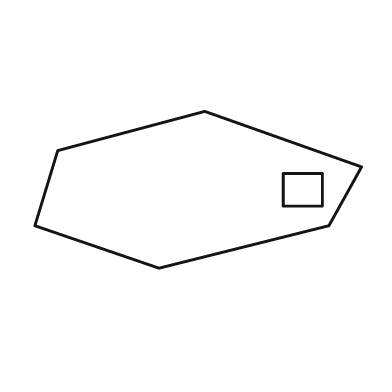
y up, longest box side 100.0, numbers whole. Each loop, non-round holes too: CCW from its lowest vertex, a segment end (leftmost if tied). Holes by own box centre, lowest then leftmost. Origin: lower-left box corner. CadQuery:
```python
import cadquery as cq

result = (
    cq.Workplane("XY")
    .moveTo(38.0, 0.0)
    .lineTo(90.0, 13.0)
    .lineTo(100.0, 31.0)
    .lineTo(52.0, 48.0)
    .lineTo(7.0, 36.0)
    .lineTo(0.0, 13.0)
    .close()
    .moveTo(76.0, 19.0)
    .lineTo(88.0, 19.0)
    .lineTo(88.0, 29.0)
    .lineTo(76.0, 29.0)
    .close()
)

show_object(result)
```